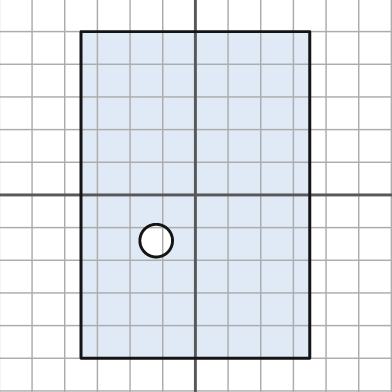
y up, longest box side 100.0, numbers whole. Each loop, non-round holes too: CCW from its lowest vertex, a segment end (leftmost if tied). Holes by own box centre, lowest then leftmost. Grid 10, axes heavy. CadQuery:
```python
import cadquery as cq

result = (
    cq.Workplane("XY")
    .moveTo(-35.0, -50.0)
    .lineTo(35.0, -50.0)
    .lineTo(35.0, 50.0)
    .lineTo(-35.0, 50.0)
    .close()
    .moveTo(-12.0, -14.0)
    .circle(5.0)
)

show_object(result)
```